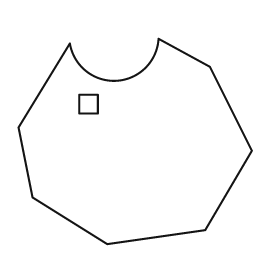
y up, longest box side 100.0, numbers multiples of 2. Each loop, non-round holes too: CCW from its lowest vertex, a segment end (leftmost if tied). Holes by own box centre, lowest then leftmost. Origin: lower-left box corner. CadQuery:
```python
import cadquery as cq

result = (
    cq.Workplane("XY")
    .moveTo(38.0, 0.0)
    .lineTo(80.0, 6.0)
    .lineTo(100.0, 40.0)
    .lineTo(82.0, 76.0)
    .lineTo(60.0, 88.0)
    .threePointArc((42.0, 70.0), (22.0, 86.0))
    .lineTo(0.0, 50.0)
    .lineTo(6.0, 20.0)
    .close()
    .moveTo(26.0, 56.0)
    .lineTo(34.0, 56.0)
    .lineTo(34.0, 64.0)
    .lineTo(26.0, 64.0)
    .close()
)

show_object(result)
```